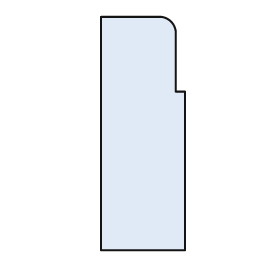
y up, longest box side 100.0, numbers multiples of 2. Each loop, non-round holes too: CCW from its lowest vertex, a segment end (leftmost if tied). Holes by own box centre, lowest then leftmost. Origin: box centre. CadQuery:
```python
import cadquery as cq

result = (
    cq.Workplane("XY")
    .moveTo(-18.0, -50.0)
    .lineTo(18.0, -50.0)
    .lineTo(18.0, 18.0)
    .lineTo(14.0, 18.0)
    .lineTo(14.0, 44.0)
    .threePointArc((12.0, 48.0), (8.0, 50.0))
    .lineTo(-18.0, 50.0)
    .close()
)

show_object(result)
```